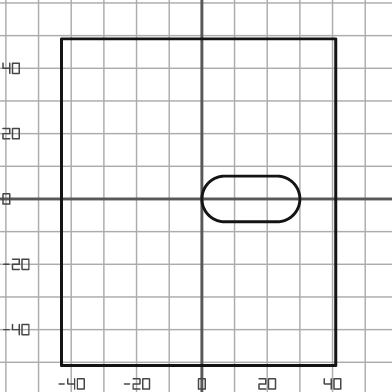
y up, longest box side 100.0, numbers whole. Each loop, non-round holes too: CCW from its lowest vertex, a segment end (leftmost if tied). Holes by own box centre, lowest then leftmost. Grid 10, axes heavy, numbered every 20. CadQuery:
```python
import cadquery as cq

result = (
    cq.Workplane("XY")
    .moveTo(-43.0, -51.0)
    .lineTo(41.0, -51.0)
    .lineTo(41.0, 49.0)
    .lineTo(-43.0, 49.0)
    .close()
    .moveTo(7.0, -7.0)
    .lineTo(23.0, -7.0)
    .threePointArc((30.0, 0.0), (23.0, 7.0))
    .lineTo(7.0, 7.0)
    .threePointArc((0.0, 0.0), (7.0, -7.0))
    .close()
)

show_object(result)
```